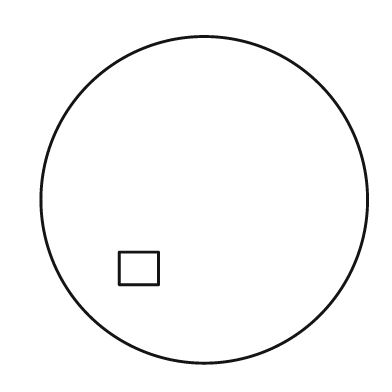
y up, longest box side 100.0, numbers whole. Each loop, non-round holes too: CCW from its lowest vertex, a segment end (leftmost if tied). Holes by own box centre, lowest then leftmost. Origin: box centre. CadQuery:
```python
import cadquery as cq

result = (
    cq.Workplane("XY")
    .moveTo(0.0, 0.0)
    .circle(50.0)
    .moveTo(-26.0, -26.0)
    .lineTo(-14.0, -26.0)
    .lineTo(-14.0, -16.0)
    .lineTo(-26.0, -16.0)
    .close()
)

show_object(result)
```